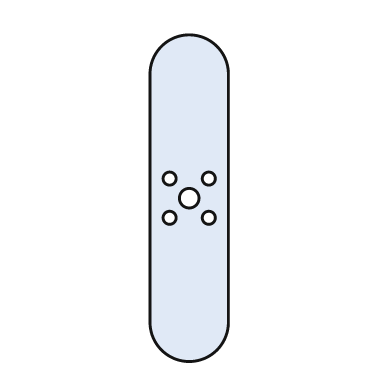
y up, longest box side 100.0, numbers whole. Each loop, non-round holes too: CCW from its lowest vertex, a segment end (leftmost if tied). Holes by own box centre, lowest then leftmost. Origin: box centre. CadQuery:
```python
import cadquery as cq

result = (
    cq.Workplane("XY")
    .moveTo(-12.0, -38.0)
    .threePointArc((0.0, -50.0), (12.0, -38.0))
    .lineTo(12.0, 38.0)
    .threePointArc((0.0, 50.0), (-12.0, 38.0))
    .close()
    .moveTo(-6.0, -6.0)
    .circle(2.0)
    .moveTo(6.0, -6.0)
    .circle(2.0)
    .moveTo(0.0, 0.0)
    .circle(3.0)
    .moveTo(-6.0, 6.0)
    .circle(2.0)
    .moveTo(6.0, 6.0)
    .circle(2.0)
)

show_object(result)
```